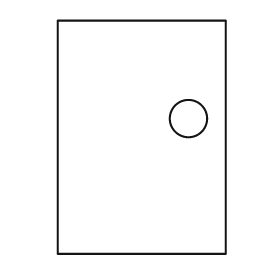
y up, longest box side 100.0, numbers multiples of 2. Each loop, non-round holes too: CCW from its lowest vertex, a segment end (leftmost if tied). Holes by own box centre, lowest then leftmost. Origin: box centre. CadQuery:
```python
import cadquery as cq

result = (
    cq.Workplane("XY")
    .moveTo(-36.0, -50.0)
    .lineTo(36.0, -50.0)
    .lineTo(36.0, 50.0)
    .lineTo(-36.0, 50.0)
    .close()
    .moveTo(20.0, 8.0)
    .circle(8.0)
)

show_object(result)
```